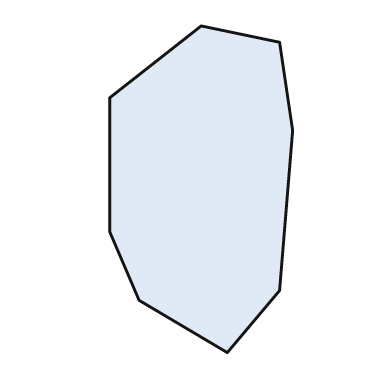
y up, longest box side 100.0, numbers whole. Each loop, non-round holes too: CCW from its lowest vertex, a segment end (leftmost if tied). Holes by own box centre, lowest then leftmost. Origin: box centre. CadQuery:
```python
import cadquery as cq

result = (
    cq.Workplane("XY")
    .moveTo(8.0, -50.0)
    .lineTo(24.0, -31.0)
    .lineTo(28.0, 18.0)
    .lineTo(24.0, 45.0)
    .lineTo(0.0, 50.0)
    .lineTo(-28.0, 28.0)
    .lineTo(-28.0, -13.0)
    .lineTo(-19.0, -34.0)
    .close()
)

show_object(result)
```